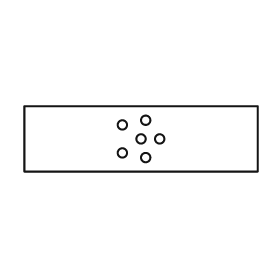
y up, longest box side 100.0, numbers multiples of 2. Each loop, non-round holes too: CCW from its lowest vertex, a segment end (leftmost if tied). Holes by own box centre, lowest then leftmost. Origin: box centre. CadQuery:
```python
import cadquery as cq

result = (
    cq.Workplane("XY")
    .moveTo(-50.0, -14.0)
    .lineTo(50.0, -14.0)
    .lineTo(50.0, 14.0)
    .lineTo(-50.0, 14.0)
    .close()
    .moveTo(2.0, -8.0)
    .circle(2.0)
    .moveTo(-8.0, -6.0)
    .circle(2.0)
    .moveTo(0.0, 0.0)
    .circle(2.0)
    .moveTo(8.0, 0.0)
    .circle(2.0)
    .moveTo(-8.0, 6.0)
    .circle(2.0)
    .moveTo(2.0, 8.0)
    .circle(2.0)
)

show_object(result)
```